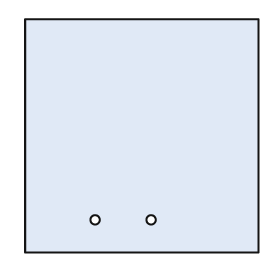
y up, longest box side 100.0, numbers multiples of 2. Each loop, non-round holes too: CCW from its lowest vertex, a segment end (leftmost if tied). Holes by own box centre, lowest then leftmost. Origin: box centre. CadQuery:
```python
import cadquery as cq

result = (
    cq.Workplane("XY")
    .moveTo(-50.0, -50.0)
    .lineTo(50.0, -50.0)
    .lineTo(50.0, 50.0)
    .lineTo(-50.0, 50.0)
    .close()
    .moveTo(-20.0, -36.0)
    .circle(2.0)
    .moveTo(4.0, -36.0)
    .circle(2.0)
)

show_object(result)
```